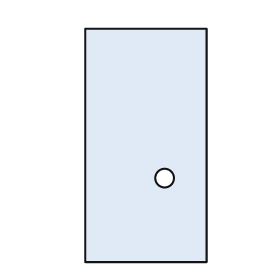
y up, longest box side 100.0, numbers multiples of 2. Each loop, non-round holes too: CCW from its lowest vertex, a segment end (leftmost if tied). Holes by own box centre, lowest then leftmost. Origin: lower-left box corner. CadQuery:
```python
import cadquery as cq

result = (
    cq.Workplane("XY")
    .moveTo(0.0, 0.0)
    .lineTo(52.0, 0.0)
    .lineTo(52.0, 100.0)
    .lineTo(0.0, 100.0)
    .close()
    .moveTo(34.0, 36.0)
    .circle(4.0)
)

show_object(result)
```